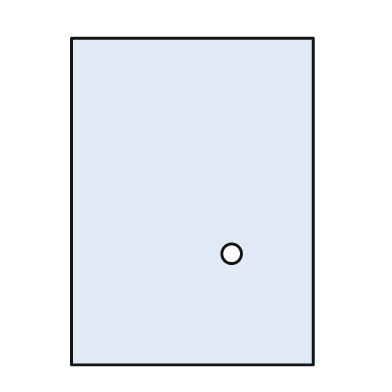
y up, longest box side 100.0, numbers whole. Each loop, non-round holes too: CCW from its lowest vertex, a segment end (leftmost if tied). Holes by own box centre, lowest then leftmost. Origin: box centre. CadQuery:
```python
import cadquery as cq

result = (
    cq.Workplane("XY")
    .moveTo(-37.0, -50.0)
    .lineTo(37.0, -50.0)
    .lineTo(37.0, 50.0)
    .lineTo(-37.0, 50.0)
    .close()
    .moveTo(12.0, -16.0)
    .circle(3.0)
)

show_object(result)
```